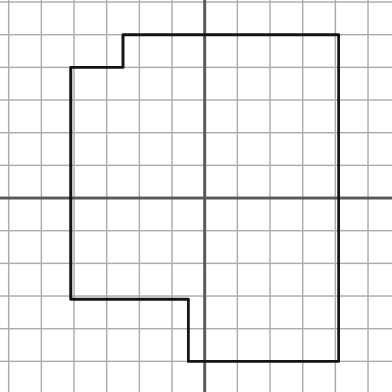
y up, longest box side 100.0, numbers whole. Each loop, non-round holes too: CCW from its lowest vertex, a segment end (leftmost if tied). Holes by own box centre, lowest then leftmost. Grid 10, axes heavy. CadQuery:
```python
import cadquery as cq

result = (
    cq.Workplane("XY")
    .moveTo(-5.0, -50.0)
    .lineTo(41.0, -50.0)
    .lineTo(41.0, 50.0)
    .lineTo(-25.0, 50.0)
    .lineTo(-25.0, 40.0)
    .lineTo(-41.0, 40.0)
    .lineTo(-41.0, -31.0)
    .lineTo(-5.0, -31.0)
    .close()
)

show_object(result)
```